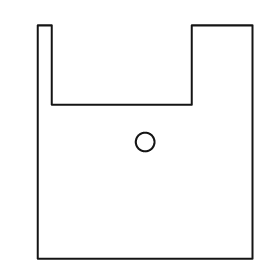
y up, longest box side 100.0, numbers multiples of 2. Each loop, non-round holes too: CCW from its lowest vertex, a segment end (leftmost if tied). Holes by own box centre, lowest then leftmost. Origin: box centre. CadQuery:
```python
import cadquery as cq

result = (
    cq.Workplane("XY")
    .moveTo(-46.0, -50.0)
    .lineTo(46.0, -50.0)
    .lineTo(46.0, 50.0)
    .lineTo(20.0, 50.0)
    .lineTo(20.0, 16.0)
    .lineTo(-40.0, 16.0)
    .lineTo(-40.0, 50.0)
    .lineTo(-46.0, 50.0)
    .close()
    .moveTo(0.0, 0.0)
    .circle(4.0)
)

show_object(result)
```